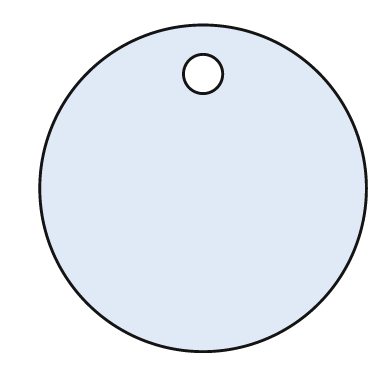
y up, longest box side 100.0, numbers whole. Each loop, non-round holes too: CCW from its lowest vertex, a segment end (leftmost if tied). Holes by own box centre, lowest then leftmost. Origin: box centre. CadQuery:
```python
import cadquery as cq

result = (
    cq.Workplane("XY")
    .moveTo(0.0, 0.0)
    .circle(50.0)
    .moveTo(0.0, 35.0)
    .circle(6.0)
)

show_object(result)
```